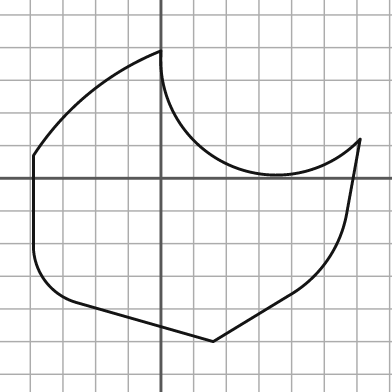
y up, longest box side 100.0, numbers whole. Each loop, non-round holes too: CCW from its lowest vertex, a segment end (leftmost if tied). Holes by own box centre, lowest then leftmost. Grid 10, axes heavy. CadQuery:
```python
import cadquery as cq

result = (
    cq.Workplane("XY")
    .moveTo(16.0, -50.0)
    .lineTo(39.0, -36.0)
    .threePointArc((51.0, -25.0), (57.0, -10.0))
    .lineTo(61.0, 12.0)
    .threePointArc((21.0, 4.0), (0.0, 39.0))
    .threePointArc((-22.0, 26.0), (-39.0, 7.0))
    .lineTo(-39.0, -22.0)
    .threePointArc((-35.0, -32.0), (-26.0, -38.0))
    .close()
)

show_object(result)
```